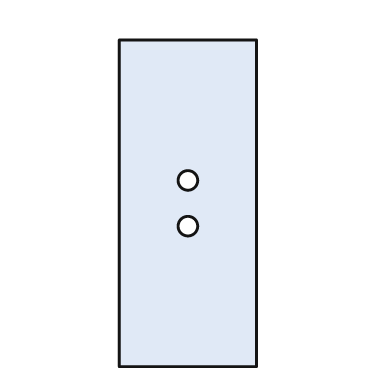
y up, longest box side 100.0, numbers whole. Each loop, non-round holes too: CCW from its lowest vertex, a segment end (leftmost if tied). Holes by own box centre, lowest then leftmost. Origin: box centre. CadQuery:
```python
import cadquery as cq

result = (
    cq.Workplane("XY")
    .moveTo(-21.0, -50.0)
    .lineTo(21.0, -50.0)
    .lineTo(21.0, 50.0)
    .lineTo(-21.0, 50.0)
    .close()
    .moveTo(0.0, -7.0)
    .circle(3.0)
    .moveTo(0.0, 7.0)
    .circle(3.0)
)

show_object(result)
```